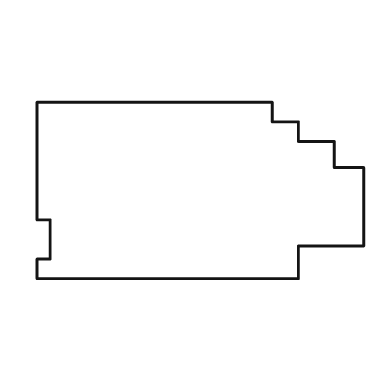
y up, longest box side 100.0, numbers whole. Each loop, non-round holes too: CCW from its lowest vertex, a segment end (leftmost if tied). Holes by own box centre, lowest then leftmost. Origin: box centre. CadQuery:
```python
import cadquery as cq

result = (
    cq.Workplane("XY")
    .moveTo(-50.0, -27.0)
    .lineTo(30.0, -27.0)
    .lineTo(30.0, -17.0)
    .lineTo(50.0, -17.0)
    .lineTo(50.0, 7.0)
    .lineTo(41.0, 7.0)
    .lineTo(41.0, 15.0)
    .lineTo(30.0, 15.0)
    .lineTo(30.0, 21.0)
    .lineTo(22.0, 21.0)
    .lineTo(22.0, 27.0)
    .lineTo(-50.0, 27.0)
    .lineTo(-50.0, -9.0)
    .lineTo(-46.0, -9.0)
    .lineTo(-46.0, -21.0)
    .lineTo(-50.0, -21.0)
    .close()
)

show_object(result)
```